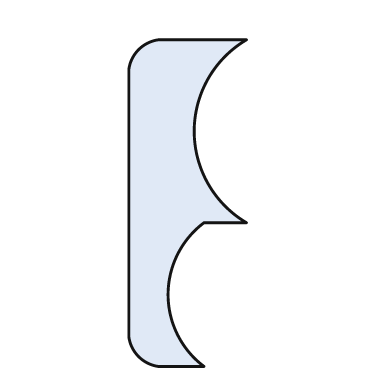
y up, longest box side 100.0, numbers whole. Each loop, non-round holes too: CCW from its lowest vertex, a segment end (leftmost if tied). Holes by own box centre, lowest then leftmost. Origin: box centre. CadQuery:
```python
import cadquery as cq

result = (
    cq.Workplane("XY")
    .moveTo(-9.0, -50.0)
    .lineTo(5.0, -50.0)
    .threePointArc((-6.0, -28.0), (5.0, -6.0))
    .lineTo(18.0, -6.0)
    .threePointArc((2.0, 22.0), (18.0, 50.0))
    .lineTo(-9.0, 50.0)
    .threePointArc((-15.0, 47.0), (-18.0, 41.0))
    .lineTo(-18.0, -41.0)
    .threePointArc((-15.0, -47.0), (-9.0, -50.0))
    .close()
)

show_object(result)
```